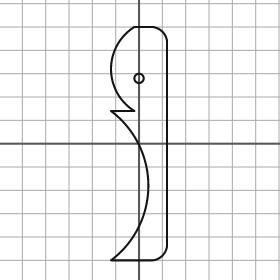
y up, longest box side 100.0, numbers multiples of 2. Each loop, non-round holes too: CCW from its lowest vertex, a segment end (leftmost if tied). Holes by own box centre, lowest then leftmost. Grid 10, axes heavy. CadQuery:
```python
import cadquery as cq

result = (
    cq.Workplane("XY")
    .moveTo(-12.0, -50.0)
    .lineTo(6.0, -50.0)
    .threePointArc((10.0, -48.0), (12.0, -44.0))
    .lineTo(12.0, 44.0)
    .threePointArc((10.0, 48.0), (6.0, 50.0))
    .lineTo(-2.0, 50.0)
    .threePointArc((-12.0, 32.0), (-2.0, 14.0))
    .lineTo(-12.0, 14.0)
    .threePointArc((4.0, -18.0), (-12.0, -50.0))
    .close()
    .moveTo(0.0, 28.0)
    .circle(2.0)
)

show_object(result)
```